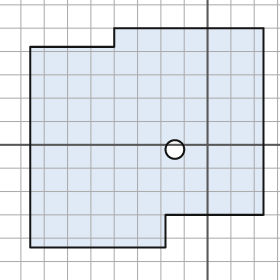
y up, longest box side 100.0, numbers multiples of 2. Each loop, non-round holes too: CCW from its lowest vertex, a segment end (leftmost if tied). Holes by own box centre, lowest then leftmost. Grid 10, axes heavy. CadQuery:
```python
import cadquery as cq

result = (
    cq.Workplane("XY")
    .moveTo(-76.0, -44.0)
    .lineTo(-18.0, -44.0)
    .lineTo(-18.0, -30.0)
    .lineTo(24.0, -30.0)
    .lineTo(24.0, 50.0)
    .lineTo(-40.0, 50.0)
    .lineTo(-40.0, 42.0)
    .lineTo(-76.0, 42.0)
    .close()
    .moveTo(-14.0, -2.0)
    .circle(4.0)
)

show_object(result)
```